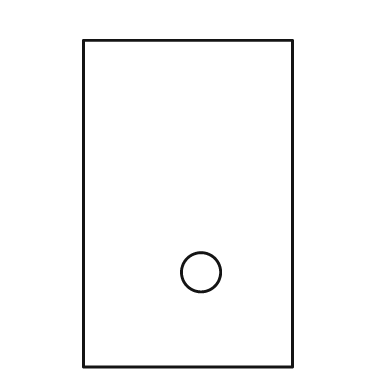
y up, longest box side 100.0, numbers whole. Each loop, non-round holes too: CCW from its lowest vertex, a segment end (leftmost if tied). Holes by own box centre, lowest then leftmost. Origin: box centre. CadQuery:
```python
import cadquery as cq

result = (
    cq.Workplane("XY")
    .moveTo(-32.0, -50.0)
    .lineTo(32.0, -50.0)
    .lineTo(32.0, 50.0)
    .lineTo(-32.0, 50.0)
    .close()
    .moveTo(4.0, -21.0)
    .circle(6.0)
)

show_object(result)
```